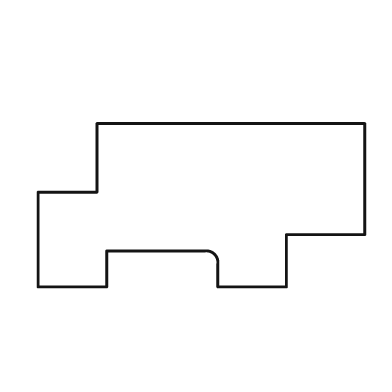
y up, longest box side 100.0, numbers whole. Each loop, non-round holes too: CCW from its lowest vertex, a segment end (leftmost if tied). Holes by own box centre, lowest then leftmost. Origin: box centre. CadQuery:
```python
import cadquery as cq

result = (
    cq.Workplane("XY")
    .moveTo(-50.0, -25.0)
    .lineTo(-29.0, -25.0)
    .lineTo(-29.0, -14.0)
    .lineTo(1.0, -14.0)
    .threePointArc((4.0, -15.0), (5.0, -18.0))
    .lineTo(5.0, -25.0)
    .lineTo(26.0, -25.0)
    .lineTo(26.0, -9.0)
    .lineTo(50.0, -9.0)
    .lineTo(50.0, 25.0)
    .lineTo(-32.0, 25.0)
    .lineTo(-32.0, 4.0)
    .lineTo(-50.0, 4.0)
    .close()
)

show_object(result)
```